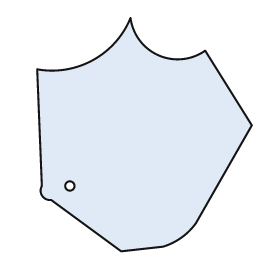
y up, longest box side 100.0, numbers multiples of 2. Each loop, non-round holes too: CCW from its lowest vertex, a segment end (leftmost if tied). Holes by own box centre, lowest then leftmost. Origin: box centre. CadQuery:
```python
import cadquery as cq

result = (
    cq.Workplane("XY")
    .moveTo(-10.0, -50.0)
    .lineTo(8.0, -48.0)
    .threePointArc((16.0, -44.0), (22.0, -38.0))
    .lineTo(46.0, 4.0)
    .lineTo(26.0, 36.0)
    .threePointArc((6.0, 34.0), (-6.0, 50.0))
    .threePointArc((-22.0, 32.0), (-46.0, 28.0))
    .lineTo(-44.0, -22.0)
    .threePointArc((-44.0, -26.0), (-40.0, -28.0))
    .close()
    .moveTo(-32.0, -22.0)
    .circle(2.0)
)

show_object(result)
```